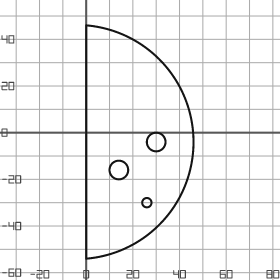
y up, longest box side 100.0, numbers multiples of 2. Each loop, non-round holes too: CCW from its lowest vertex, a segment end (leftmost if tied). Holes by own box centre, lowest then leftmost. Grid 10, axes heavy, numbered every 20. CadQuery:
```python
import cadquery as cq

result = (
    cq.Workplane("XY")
    .moveTo(0.0, -54.0)
    .threePointArc((46.0, -4.0), (0.0, 46.0))
    .close()
    .moveTo(26.0, -30.0)
    .circle(2.0)
    .moveTo(14.0, -16.0)
    .circle(4.0)
    .moveTo(30.0, -4.0)
    .circle(4.0)
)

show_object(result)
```